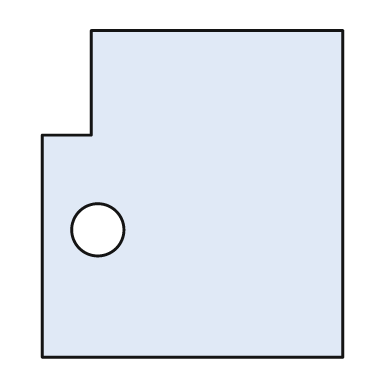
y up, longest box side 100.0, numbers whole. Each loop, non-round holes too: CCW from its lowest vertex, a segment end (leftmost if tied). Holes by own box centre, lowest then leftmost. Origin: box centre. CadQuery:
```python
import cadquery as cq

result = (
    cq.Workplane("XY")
    .moveTo(-46.0, -50.0)
    .lineTo(46.0, -50.0)
    .lineTo(46.0, 50.0)
    .lineTo(-31.0, 50.0)
    .lineTo(-31.0, 18.0)
    .lineTo(-46.0, 18.0)
    .close()
    .moveTo(-29.0, -11.0)
    .circle(8.0)
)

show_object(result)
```